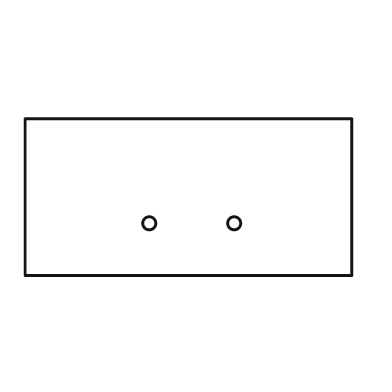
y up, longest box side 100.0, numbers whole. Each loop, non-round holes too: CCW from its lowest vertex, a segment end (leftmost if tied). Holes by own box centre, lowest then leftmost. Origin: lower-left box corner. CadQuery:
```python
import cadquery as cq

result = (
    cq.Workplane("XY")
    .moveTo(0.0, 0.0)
    .lineTo(100.0, 0.0)
    .lineTo(100.0, 48.0)
    .lineTo(0.0, 48.0)
    .close()
    .moveTo(38.0, 16.0)
    .circle(2.0)
    .moveTo(64.0, 16.0)
    .circle(2.0)
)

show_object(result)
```